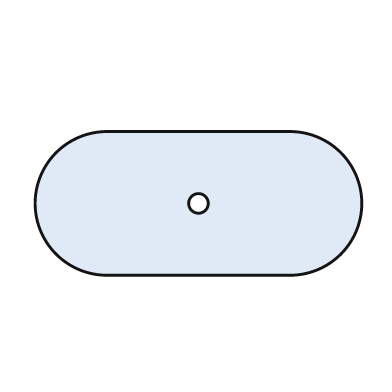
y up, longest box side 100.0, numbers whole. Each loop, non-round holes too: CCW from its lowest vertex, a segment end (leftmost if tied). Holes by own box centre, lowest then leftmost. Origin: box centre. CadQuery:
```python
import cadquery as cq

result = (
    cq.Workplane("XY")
    .moveTo(-28.0, -22.0)
    .lineTo(28.0, -22.0)
    .threePointArc((50.0, 0.0), (28.0, 22.0))
    .lineTo(-28.0, 22.0)
    .threePointArc((-50.0, 0.0), (-28.0, -22.0))
    .close()
    .moveTo(0.0, 0.0)
    .circle(3.0)
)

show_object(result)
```